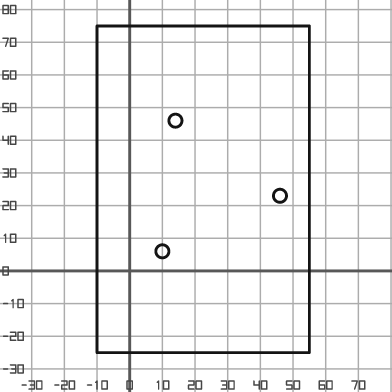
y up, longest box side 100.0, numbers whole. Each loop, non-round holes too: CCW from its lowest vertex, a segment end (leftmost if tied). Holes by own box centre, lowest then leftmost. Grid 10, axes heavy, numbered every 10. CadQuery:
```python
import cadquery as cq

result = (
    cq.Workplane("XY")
    .moveTo(-10.0, -25.0)
    .lineTo(55.0, -25.0)
    .lineTo(55.0, 75.0)
    .lineTo(-10.0, 75.0)
    .close()
    .moveTo(10.0, 6.0)
    .circle(2.0)
    .moveTo(46.0, 23.0)
    .circle(2.0)
    .moveTo(14.0, 46.0)
    .circle(2.0)
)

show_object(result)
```